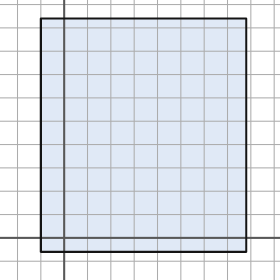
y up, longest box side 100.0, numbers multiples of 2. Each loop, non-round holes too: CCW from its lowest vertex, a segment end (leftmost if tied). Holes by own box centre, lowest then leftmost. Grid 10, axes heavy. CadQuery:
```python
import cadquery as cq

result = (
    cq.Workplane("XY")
    .moveTo(-10.0, -6.0)
    .lineTo(78.0, -6.0)
    .lineTo(78.0, 94.0)
    .lineTo(-10.0, 94.0)
    .close()
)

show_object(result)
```